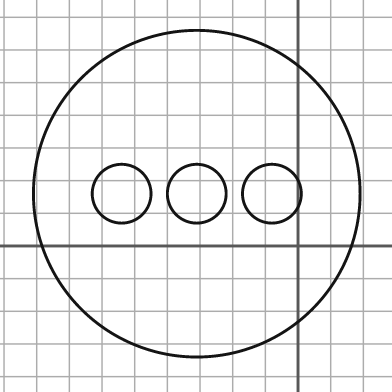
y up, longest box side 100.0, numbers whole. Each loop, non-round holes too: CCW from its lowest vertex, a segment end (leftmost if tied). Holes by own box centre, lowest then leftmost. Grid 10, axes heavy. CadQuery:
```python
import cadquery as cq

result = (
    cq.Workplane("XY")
    .moveTo(-31.0, 16.0)
    .circle(50.0)
    .moveTo(-54.0, 16.0)
    .circle(9.0)
    .moveTo(-31.0, 16.0)
    .circle(9.0)
    .moveTo(-8.0, 16.0)
    .circle(9.0)
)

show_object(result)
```